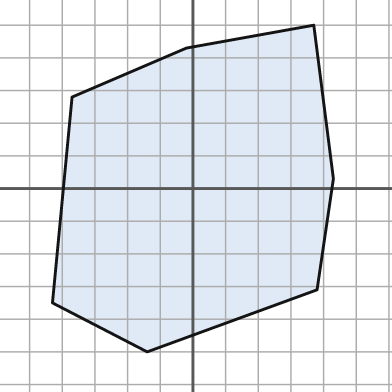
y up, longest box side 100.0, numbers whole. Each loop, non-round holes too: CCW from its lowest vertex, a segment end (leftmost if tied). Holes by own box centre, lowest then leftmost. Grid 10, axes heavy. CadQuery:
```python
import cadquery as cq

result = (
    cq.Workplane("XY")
    .moveTo(-14.0, -50.0)
    .lineTo(38.0, -31.0)
    .lineTo(43.0, 3.0)
    .lineTo(37.0, 50.0)
    .lineTo(-2.0, 43.0)
    .lineTo(-37.0, 28.0)
    .lineTo(-43.0, -35.0)
    .close()
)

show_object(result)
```